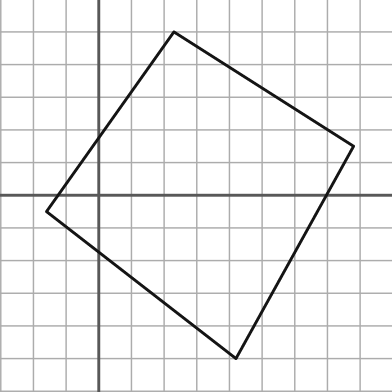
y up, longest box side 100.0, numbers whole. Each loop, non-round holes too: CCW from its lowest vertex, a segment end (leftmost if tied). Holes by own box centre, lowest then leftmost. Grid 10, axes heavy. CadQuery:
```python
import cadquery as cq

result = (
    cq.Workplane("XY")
    .moveTo(42.0, -50.0)
    .lineTo(78.0, 15.0)
    .lineTo(23.0, 50.0)
    .lineTo(-16.0, -5.0)
    .close()
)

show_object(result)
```